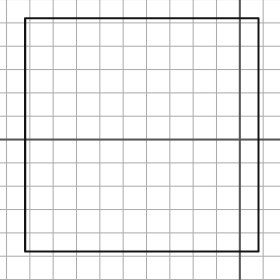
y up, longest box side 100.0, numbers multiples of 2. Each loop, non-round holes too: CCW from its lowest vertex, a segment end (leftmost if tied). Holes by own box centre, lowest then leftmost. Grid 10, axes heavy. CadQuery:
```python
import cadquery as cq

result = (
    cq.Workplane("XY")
    .moveTo(-92.0, -48.0)
    .lineTo(8.0, -48.0)
    .lineTo(8.0, 52.0)
    .lineTo(-92.0, 52.0)
    .close()
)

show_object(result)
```